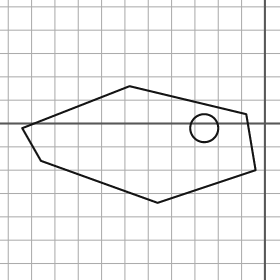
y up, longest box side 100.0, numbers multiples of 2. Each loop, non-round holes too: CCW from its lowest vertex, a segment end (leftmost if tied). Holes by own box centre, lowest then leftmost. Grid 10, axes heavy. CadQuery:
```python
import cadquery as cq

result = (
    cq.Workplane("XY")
    .moveTo(-46.0, -34.0)
    .lineTo(-4.0, -20.0)
    .lineTo(-8.0, 4.0)
    .lineTo(-58.0, 16.0)
    .lineTo(-104.0, -2.0)
    .lineTo(-96.0, -16.0)
    .close()
    .moveTo(-26.0, -2.0)
    .circle(6.0)
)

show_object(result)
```